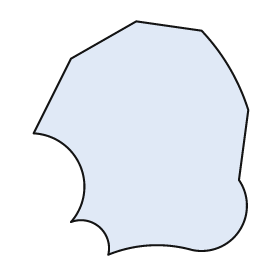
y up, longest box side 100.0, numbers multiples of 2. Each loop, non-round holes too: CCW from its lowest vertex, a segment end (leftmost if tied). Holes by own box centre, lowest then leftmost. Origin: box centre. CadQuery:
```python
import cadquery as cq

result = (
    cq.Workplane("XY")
    .moveTo(-14.0, -50.0)
    .threePointArc((4.0, -46.0), (22.0, -48.0))
    .threePointArc((42.0, -40.0), (42.0, -18.0))
    .lineTo(46.0, 12.0)
    .threePointArc((38.0, 30.0), (26.0, 46.0))
    .lineTo(-2.0, 50.0)
    .lineTo(-30.0, 34.0)
    .lineTo(-46.0, 2.0)
    .threePointArc((-26.0, -12.0), (-30.0, -36.0))
    .threePointArc((-18.0, -38.0), (-14.0, -50.0))
    .close()
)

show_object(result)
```